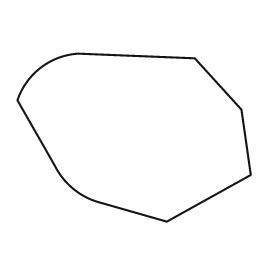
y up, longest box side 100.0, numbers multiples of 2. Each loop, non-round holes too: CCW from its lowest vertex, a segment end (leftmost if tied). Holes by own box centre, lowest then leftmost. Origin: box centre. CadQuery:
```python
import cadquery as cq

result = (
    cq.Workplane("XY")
    .moveTo(14.0, -36.0)
    .lineTo(50.0, -16.0)
    .lineTo(46.0, 12.0)
    .lineTo(26.0, 34.0)
    .lineTo(-24.0, 36.0)
    .threePointArc((-40.0, 30.0), (-50.0, 16.0))
    .lineTo(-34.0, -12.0)
    .threePointArc((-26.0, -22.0), (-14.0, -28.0))
    .close()
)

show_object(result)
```